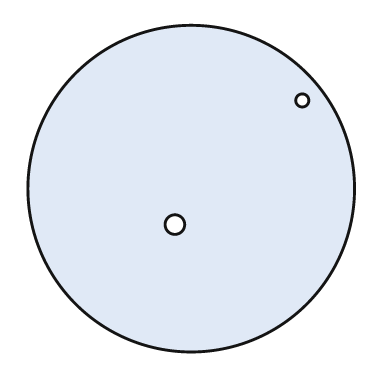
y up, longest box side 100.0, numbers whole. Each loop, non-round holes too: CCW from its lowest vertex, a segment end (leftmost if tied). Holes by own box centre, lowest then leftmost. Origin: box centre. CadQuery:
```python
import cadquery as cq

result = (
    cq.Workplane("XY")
    .moveTo(0.0, 0.0)
    .circle(50.0)
    .moveTo(-5.0, -11.0)
    .circle(3.0)
    .moveTo(34.0, 27.0)
    .circle(2.0)
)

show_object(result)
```